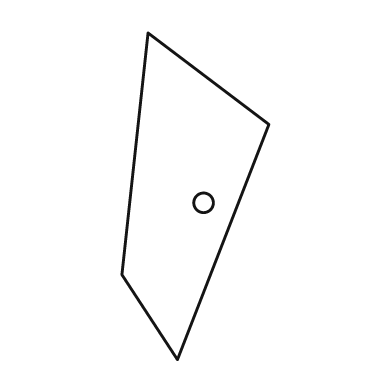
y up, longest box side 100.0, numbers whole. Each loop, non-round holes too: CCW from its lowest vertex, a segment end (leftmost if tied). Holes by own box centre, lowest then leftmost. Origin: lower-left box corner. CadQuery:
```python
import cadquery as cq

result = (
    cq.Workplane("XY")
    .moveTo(17.0, 0.0)
    .lineTo(45.0, 72.0)
    .lineTo(8.0, 100.0)
    .lineTo(0.0, 26.0)
    .close()
    .moveTo(25.0, 48.0)
    .circle(3.0)
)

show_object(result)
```